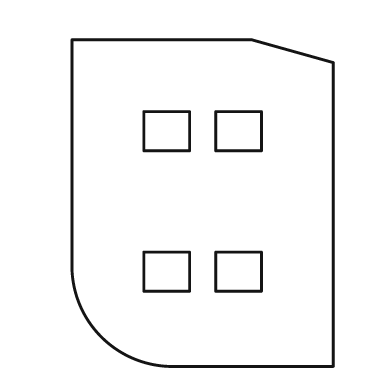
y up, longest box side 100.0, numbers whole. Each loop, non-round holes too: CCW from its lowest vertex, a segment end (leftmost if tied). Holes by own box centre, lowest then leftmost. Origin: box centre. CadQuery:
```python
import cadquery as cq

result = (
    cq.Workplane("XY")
    .moveTo(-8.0, -50.0)
    .lineTo(40.0, -50.0)
    .lineTo(40.0, 43.0)
    .lineTo(15.0, 50.0)
    .lineTo(-40.0, 50.0)
    .lineTo(-40.0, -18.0)
    .threePointArc((-31.0, -41.0), (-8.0, -50.0))
    .close()
    .moveTo(-18.0, -27.0)
    .lineTo(-4.0, -27.0)
    .lineTo(-4.0, -15.0)
    .lineTo(-18.0, -15.0)
    .close()
    .moveTo(4.0, -27.0)
    .lineTo(18.0, -27.0)
    .lineTo(18.0, -15.0)
    .lineTo(4.0, -15.0)
    .close()
    .moveTo(-18.0, 16.0)
    .lineTo(-4.0, 16.0)
    .lineTo(-4.0, 28.0)
    .lineTo(-18.0, 28.0)
    .close()
    .moveTo(4.0, 16.0)
    .lineTo(18.0, 16.0)
    .lineTo(18.0, 28.0)
    .lineTo(4.0, 28.0)
    .close()
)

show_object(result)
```